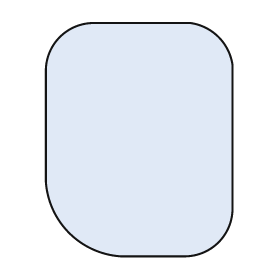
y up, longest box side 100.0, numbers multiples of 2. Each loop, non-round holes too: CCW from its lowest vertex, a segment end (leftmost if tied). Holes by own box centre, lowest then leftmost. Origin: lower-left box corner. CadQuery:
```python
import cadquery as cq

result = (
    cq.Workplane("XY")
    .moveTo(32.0, 0.0)
    .lineTo(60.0, 0.0)
    .threePointArc((74.0, 6.0), (80.0, 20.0))
    .lineTo(80.0, 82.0)
    .threePointArc((74.0, 94.0), (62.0, 100.0))
    .lineTo(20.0, 100.0)
    .threePointArc((6.0, 94.0), (0.0, 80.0))
    .lineTo(0.0, 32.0)
    .threePointArc((10.0, 10.0), (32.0, 0.0))
    .close()
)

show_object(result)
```